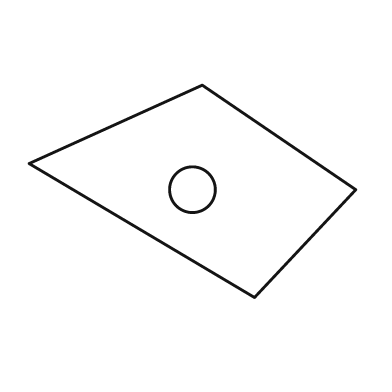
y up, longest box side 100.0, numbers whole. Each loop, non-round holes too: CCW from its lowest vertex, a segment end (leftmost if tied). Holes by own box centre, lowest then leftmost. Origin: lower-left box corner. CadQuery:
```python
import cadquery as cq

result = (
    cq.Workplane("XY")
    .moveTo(69.0, 0.0)
    .lineTo(100.0, 33.0)
    .lineTo(53.0, 65.0)
    .lineTo(0.0, 41.0)
    .close()
    .moveTo(50.0, 33.0)
    .circle(7.0)
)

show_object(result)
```